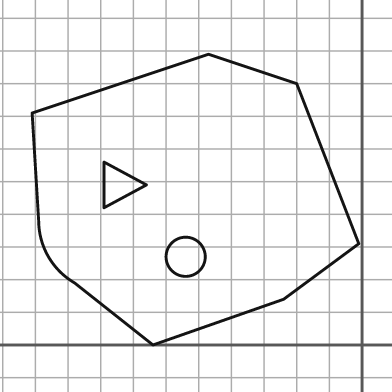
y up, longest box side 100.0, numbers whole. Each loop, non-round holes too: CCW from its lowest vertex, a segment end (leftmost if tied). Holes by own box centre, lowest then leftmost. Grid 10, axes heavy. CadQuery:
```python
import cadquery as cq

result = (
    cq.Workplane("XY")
    .moveTo(-64.0, 0.0)
    .lineTo(-24.0, 14.0)
    .lineTo(-1.0, 31.0)
    .lineTo(-20.0, 80.0)
    .lineTo(-47.0, 89.0)
    .lineTo(-101.0, 71.0)
    .lineTo(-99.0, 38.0)
    .threePointArc((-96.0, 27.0), (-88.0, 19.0))
    .close()
    .moveTo(-54.0, 27.0)
    .circle(6.0)
    .moveTo(-79.0, 42.0)
    .lineTo(-66.0, 49.0)
    .lineTo(-79.0, 56.0)
    .close()
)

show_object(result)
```